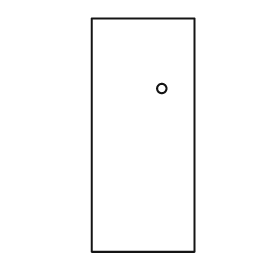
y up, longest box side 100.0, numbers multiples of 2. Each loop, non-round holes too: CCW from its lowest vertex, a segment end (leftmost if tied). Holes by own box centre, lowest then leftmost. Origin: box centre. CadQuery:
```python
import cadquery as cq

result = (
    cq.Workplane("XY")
    .moveTo(-22.0, -50.0)
    .lineTo(22.0, -50.0)
    .lineTo(22.0, 50.0)
    .lineTo(-22.0, 50.0)
    .close()
    .moveTo(8.0, 20.0)
    .circle(2.0)
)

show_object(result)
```